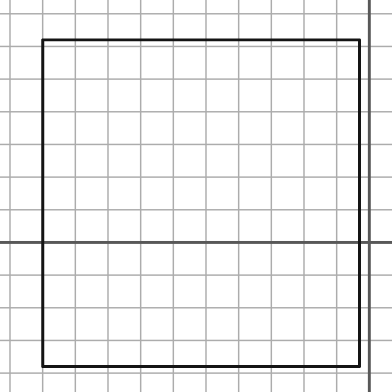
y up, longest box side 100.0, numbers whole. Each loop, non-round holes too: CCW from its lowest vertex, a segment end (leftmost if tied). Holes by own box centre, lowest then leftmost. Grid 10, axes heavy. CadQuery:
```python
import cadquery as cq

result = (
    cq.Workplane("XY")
    .moveTo(-100.0, -38.0)
    .lineTo(-3.0, -38.0)
    .lineTo(-3.0, 62.0)
    .lineTo(-100.0, 62.0)
    .close()
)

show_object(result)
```